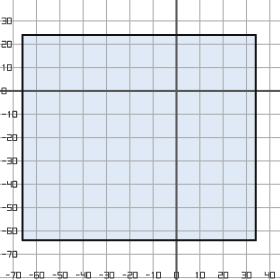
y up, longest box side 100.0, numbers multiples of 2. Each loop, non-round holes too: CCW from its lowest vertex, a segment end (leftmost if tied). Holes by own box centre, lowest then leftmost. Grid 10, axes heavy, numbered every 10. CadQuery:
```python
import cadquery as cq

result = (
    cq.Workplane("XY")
    .moveTo(-66.0, -64.0)
    .lineTo(34.0, -64.0)
    .lineTo(34.0, 24.0)
    .lineTo(-66.0, 24.0)
    .close()
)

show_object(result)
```